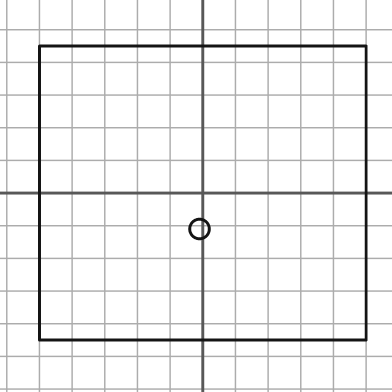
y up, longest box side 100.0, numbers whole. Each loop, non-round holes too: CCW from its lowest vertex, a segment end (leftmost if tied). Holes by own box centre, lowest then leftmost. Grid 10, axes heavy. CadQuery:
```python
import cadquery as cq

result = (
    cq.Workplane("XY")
    .moveTo(-50.0, -45.0)
    .lineTo(50.0, -45.0)
    .lineTo(50.0, 45.0)
    .lineTo(-50.0, 45.0)
    .close()
    .moveTo(-1.0, -11.0)
    .circle(3.0)
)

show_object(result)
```